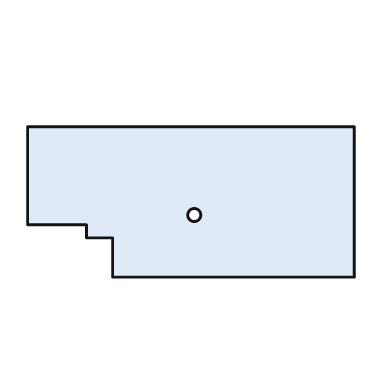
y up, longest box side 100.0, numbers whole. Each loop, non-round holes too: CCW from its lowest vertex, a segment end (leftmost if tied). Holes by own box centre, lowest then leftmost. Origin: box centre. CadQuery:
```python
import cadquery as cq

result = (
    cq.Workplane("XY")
    .moveTo(-24.0, -23.0)
    .lineTo(50.0, -23.0)
    .lineTo(50.0, 23.0)
    .lineTo(-50.0, 23.0)
    .lineTo(-50.0, -7.0)
    .lineTo(-32.0, -7.0)
    .lineTo(-32.0, -11.0)
    .lineTo(-24.0, -11.0)
    .close()
    .moveTo(1.0, -4.0)
    .circle(2.0)
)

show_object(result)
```